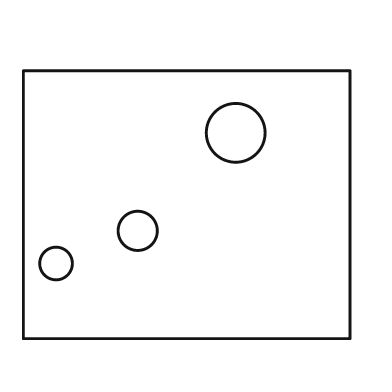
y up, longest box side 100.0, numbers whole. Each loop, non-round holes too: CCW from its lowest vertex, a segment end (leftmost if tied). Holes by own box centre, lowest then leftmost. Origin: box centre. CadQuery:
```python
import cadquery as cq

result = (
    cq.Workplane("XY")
    .moveTo(-50.0, -41.0)
    .lineTo(50.0, -41.0)
    .lineTo(50.0, 41.0)
    .lineTo(-50.0, 41.0)
    .close()
    .moveTo(-40.0, -18.0)
    .circle(5.0)
    .moveTo(-15.0, -8.0)
    .circle(6.0)
    .moveTo(15.0, 22.0)
    .circle(9.0)
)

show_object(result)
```